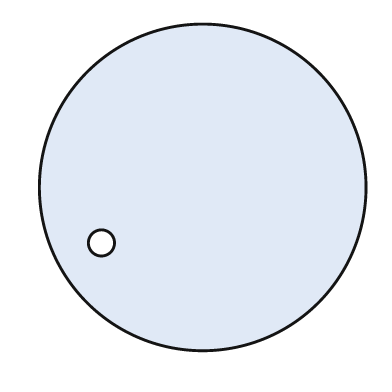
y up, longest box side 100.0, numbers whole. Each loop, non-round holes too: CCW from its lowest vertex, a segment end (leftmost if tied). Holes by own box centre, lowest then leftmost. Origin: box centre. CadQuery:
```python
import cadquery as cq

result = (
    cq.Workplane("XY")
    .moveTo(0.0, 0.0)
    .circle(50.0)
    .moveTo(-31.0, -17.0)
    .circle(4.0)
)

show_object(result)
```